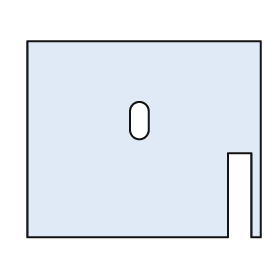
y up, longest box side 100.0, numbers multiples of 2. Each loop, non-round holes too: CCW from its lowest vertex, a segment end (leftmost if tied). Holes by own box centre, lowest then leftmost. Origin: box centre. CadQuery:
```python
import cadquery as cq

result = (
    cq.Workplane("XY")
    .moveTo(-50.0, -42.0)
    .lineTo(36.0, -42.0)
    .lineTo(36.0, -6.0)
    .lineTo(46.0, -6.0)
    .lineTo(46.0, -42.0)
    .lineTo(50.0, -42.0)
    .lineTo(50.0, 42.0)
    .lineTo(-50.0, 42.0)
    .close()
    .moveTo(-6.0, 4.0)
    .threePointArc((-2.0, 0.0), (2.0, 4.0))
    .lineTo(2.0, 12.0)
    .threePointArc((-2.0, 16.0), (-6.0, 12.0))
    .close()
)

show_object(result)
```